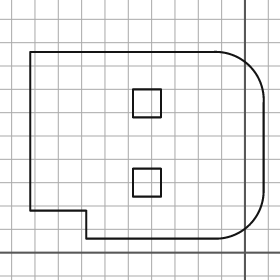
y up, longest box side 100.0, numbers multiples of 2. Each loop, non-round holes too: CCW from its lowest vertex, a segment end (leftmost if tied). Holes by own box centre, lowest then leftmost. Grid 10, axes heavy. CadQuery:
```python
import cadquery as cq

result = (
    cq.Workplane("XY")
    .moveTo(-68.0, 6.0)
    .lineTo(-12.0, 6.0)
    .threePointArc((2.0, 12.0), (8.0, 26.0))
    .lineTo(8.0, 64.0)
    .threePointArc((2.0, 80.0), (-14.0, 86.0))
    .lineTo(-92.0, 86.0)
    .lineTo(-92.0, 18.0)
    .lineTo(-68.0, 18.0)
    .close()
    .moveTo(-48.0, 24.0)
    .lineTo(-36.0, 24.0)
    .lineTo(-36.0, 36.0)
    .lineTo(-48.0, 36.0)
    .close()
    .moveTo(-48.0, 58.0)
    .lineTo(-36.0, 58.0)
    .lineTo(-36.0, 70.0)
    .lineTo(-48.0, 70.0)
    .close()
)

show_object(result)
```